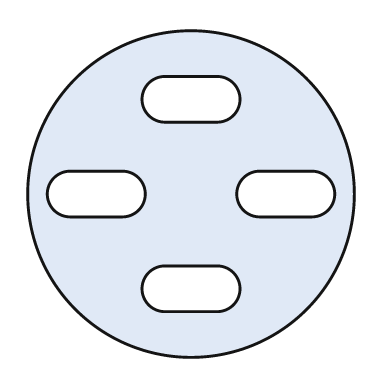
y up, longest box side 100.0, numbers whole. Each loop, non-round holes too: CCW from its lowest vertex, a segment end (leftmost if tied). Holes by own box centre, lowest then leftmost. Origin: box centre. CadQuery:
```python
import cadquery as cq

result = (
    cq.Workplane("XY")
    .moveTo(0.0, 0.0)
    .circle(50.0)
    .moveTo(-8.0, -36.0)
    .lineTo(8.0, -36.0)
    .threePointArc((15.0, -29.0), (8.0, -22.0))
    .lineTo(-8.0, -22.0)
    .threePointArc((-15.0, -29.0), (-8.0, -36.0))
    .close()
    .moveTo(-37.0, -7.0)
    .lineTo(-21.0, -7.0)
    .threePointArc((-14.0, 0.0), (-21.0, 7.0))
    .lineTo(-37.0, 7.0)
    .threePointArc((-44.0, 0.0), (-37.0, -7.0))
    .close()
    .moveTo(21.0, -7.0)
    .lineTo(37.0, -7.0)
    .threePointArc((44.0, 0.0), (37.0, 7.0))
    .lineTo(21.0, 7.0)
    .threePointArc((14.0, 0.0), (21.0, -7.0))
    .close()
    .moveTo(-8.0, 22.0)
    .lineTo(8.0, 22.0)
    .threePointArc((15.0, 29.0), (8.0, 36.0))
    .lineTo(-8.0, 36.0)
    .threePointArc((-15.0, 29.0), (-8.0, 22.0))
    .close()
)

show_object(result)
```